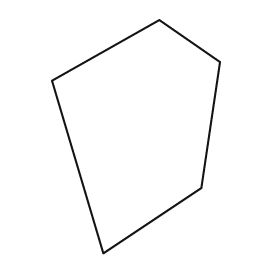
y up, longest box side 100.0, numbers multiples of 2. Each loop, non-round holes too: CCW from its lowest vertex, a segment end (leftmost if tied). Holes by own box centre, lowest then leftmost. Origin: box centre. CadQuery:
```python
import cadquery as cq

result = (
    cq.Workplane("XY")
    .moveTo(-14.0, -50.0)
    .lineTo(28.0, -22.0)
    .lineTo(36.0, 32.0)
    .lineTo(10.0, 50.0)
    .lineTo(-36.0, 24.0)
    .close()
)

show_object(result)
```